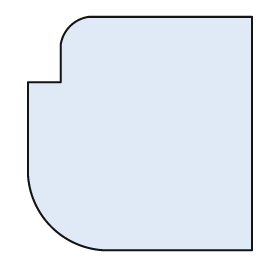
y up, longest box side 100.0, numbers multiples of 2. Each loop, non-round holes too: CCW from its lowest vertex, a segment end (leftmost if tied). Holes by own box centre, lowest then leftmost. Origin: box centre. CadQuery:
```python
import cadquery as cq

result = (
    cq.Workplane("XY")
    .moveTo(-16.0, -50.0)
    .lineTo(48.0, -50.0)
    .lineTo(48.0, 50.0)
    .lineTo(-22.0, 50.0)
    .threePointArc((-30.0, 46.0), (-34.0, 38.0))
    .lineTo(-34.0, 22.0)
    .lineTo(-48.0, 22.0)
    .lineTo(-48.0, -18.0)
    .threePointArc((-38.0, -40.0), (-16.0, -50.0))
    .close()
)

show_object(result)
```